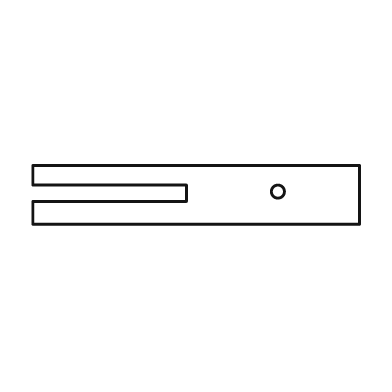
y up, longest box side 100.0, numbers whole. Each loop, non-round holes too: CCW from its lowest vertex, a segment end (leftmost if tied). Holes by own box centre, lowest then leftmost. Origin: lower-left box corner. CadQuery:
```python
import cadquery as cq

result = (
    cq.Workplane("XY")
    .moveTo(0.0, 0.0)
    .lineTo(100.0, 0.0)
    .lineTo(100.0, 18.0)
    .lineTo(0.0, 18.0)
    .lineTo(0.0, 12.0)
    .lineTo(47.0, 12.0)
    .lineTo(47.0, 7.0)
    .lineTo(0.0, 7.0)
    .close()
    .moveTo(75.0, 10.0)
    .circle(2.0)
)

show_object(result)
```